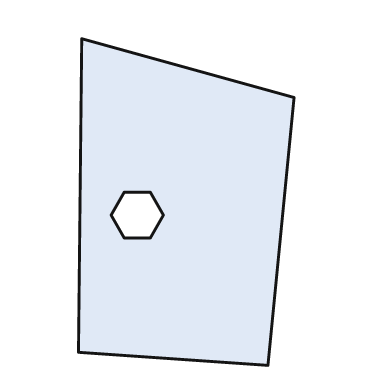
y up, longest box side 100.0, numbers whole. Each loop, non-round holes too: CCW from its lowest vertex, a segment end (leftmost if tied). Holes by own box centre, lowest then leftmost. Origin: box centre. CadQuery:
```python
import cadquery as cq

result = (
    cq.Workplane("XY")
    .moveTo(25.0, -50.0)
    .lineTo(33.0, 32.0)
    .lineTo(-32.0, 50.0)
    .lineTo(-33.0, -46.0)
    .close()
    .moveTo(-19.0, -11.0)
    .lineTo(-11.0, -11.0)
    .lineTo(-7.0, -4.0)
    .lineTo(-11.0, 3.0)
    .lineTo(-19.0, 3.0)
    .lineTo(-23.0, -4.0)
    .close()
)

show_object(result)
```